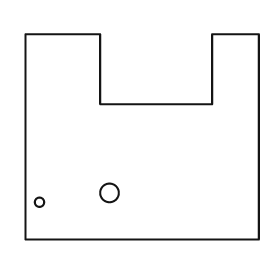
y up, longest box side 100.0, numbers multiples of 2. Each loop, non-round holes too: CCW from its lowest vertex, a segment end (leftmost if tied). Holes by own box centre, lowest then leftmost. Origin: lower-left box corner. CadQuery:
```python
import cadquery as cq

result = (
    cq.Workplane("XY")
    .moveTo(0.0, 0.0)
    .lineTo(100.0, 0.0)
    .lineTo(100.0, 88.0)
    .lineTo(80.0, 88.0)
    .lineTo(80.0, 58.0)
    .lineTo(32.0, 58.0)
    .lineTo(32.0, 88.0)
    .lineTo(0.0, 88.0)
    .close()
    .moveTo(6.0, 16.0)
    .circle(2.0)
    .moveTo(36.0, 20.0)
    .circle(4.0)
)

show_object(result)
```